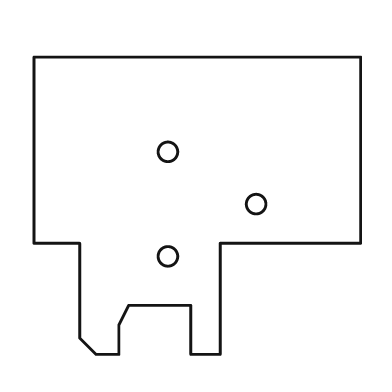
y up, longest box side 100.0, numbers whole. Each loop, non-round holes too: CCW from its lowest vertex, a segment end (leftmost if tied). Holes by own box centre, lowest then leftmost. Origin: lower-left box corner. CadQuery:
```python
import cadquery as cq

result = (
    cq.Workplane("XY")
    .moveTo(19.0, 0.0)
    .lineTo(26.0, 0.0)
    .lineTo(26.0, 9.0)
    .lineTo(29.0, 15.0)
    .lineTo(48.0, 15.0)
    .lineTo(48.0, 0.0)
    .lineTo(57.0, 0.0)
    .lineTo(57.0, 34.0)
    .lineTo(100.0, 34.0)
    .lineTo(100.0, 91.0)
    .lineTo(0.0, 91.0)
    .lineTo(0.0, 34.0)
    .lineTo(14.0, 34.0)
    .lineTo(14.0, 5.0)
    .close()
    .moveTo(41.0, 30.0)
    .circle(3.0)
    .moveTo(68.0, 46.0)
    .circle(3.0)
    .moveTo(41.0, 62.0)
    .circle(3.0)
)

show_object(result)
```